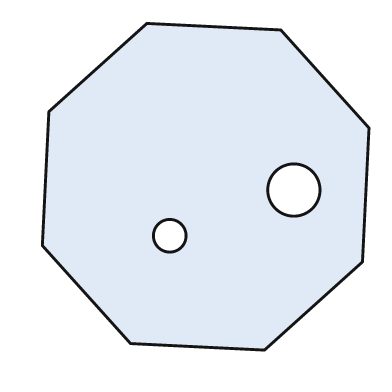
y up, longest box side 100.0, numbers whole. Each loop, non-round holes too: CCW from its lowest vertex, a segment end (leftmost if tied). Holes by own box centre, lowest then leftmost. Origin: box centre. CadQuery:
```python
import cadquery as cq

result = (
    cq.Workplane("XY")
    .moveTo(18.0, -50.0)
    .lineTo(48.0, -23.0)
    .lineTo(50.0, 18.0)
    .lineTo(23.0, 48.0)
    .lineTo(-18.0, 50.0)
    .lineTo(-48.0, 23.0)
    .lineTo(-50.0, -18.0)
    .lineTo(-23.0, -48.0)
    .close()
    .moveTo(-11.0, -15.0)
    .circle(5.0)
    .moveTo(27.0, -1.0)
    .circle(8.0)
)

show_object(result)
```